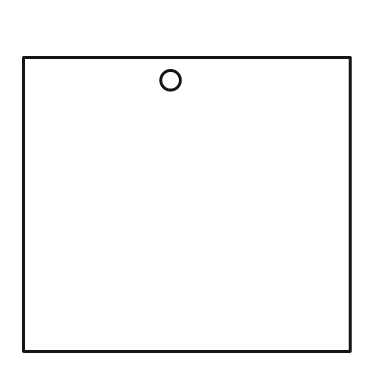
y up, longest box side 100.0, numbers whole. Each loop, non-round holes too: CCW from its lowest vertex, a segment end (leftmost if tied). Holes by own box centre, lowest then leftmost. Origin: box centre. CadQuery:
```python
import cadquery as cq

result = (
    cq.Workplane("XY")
    .moveTo(-50.0, -45.0)
    .lineTo(50.0, -45.0)
    .lineTo(50.0, 45.0)
    .lineTo(-50.0, 45.0)
    .close()
    .moveTo(-5.0, 38.0)
    .circle(3.0)
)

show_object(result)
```